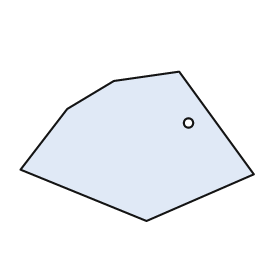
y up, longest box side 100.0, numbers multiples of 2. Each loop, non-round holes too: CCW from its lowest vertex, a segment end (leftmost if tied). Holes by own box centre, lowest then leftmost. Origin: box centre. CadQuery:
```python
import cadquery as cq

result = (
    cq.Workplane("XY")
    .moveTo(4.0, -32.0)
    .lineTo(50.0, -12.0)
    .lineTo(18.0, 32.0)
    .lineTo(-10.0, 28.0)
    .lineTo(-30.0, 16.0)
    .lineTo(-50.0, -10.0)
    .close()
    .moveTo(22.0, 10.0)
    .circle(2.0)
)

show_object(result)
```